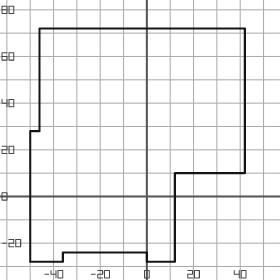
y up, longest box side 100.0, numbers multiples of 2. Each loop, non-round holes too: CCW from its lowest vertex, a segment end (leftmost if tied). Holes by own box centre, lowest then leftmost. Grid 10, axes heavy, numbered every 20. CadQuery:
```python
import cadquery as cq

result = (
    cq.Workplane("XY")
    .moveTo(-50.0, -28.0)
    .lineTo(-36.0, -28.0)
    .lineTo(-36.0, -24.0)
    .lineTo(0.0, -24.0)
    .lineTo(0.0, -28.0)
    .lineTo(12.0, -28.0)
    .lineTo(12.0, 10.0)
    .lineTo(42.0, 10.0)
    .lineTo(42.0, 72.0)
    .lineTo(-46.0, 72.0)
    .lineTo(-46.0, 28.0)
    .lineTo(-50.0, 28.0)
    .close()
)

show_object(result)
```